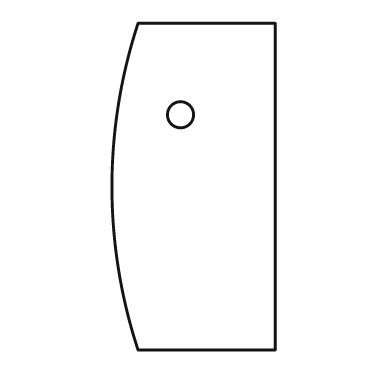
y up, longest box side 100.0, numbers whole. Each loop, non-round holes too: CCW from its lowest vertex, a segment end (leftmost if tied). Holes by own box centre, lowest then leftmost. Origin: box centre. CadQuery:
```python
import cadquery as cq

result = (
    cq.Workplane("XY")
    .moveTo(-17.0, -50.0)
    .lineTo(25.0, -50.0)
    .lineTo(25.0, 50.0)
    .lineTo(-17.0, 50.0)
    .threePointArc((-25.0, 0.0), (-17.0, -50.0))
    .close()
    .moveTo(-4.0, 22.0)
    .circle(4.0)
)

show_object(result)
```